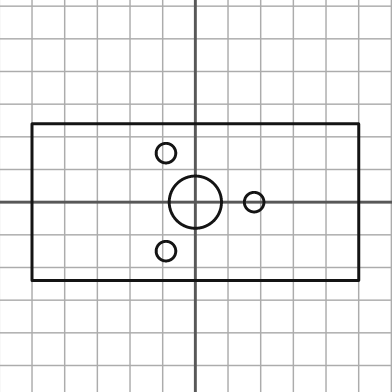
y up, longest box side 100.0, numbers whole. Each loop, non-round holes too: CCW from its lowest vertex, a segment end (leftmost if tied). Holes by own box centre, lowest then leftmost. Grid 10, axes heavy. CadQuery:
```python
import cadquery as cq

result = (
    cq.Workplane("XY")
    .moveTo(-50.0, -24.0)
    .lineTo(50.0, -24.0)
    .lineTo(50.0, 24.0)
    .lineTo(-50.0, 24.0)
    .close()
    .moveTo(-9.0, -15.0)
    .circle(3.0)
    .moveTo(0.0, 0.0)
    .circle(8.0)
    .moveTo(18.0, 0.0)
    .circle(3.0)
    .moveTo(-9.0, 15.0)
    .circle(3.0)
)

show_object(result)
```